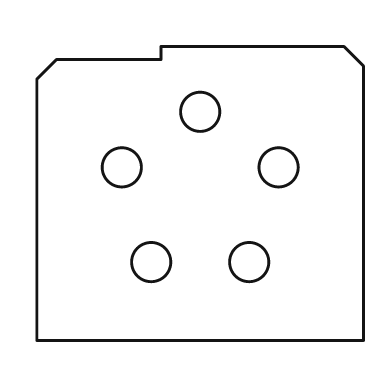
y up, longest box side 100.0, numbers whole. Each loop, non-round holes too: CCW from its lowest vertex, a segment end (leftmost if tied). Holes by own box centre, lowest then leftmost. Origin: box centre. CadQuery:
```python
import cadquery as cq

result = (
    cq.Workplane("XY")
    .moveTo(-50.0, -45.0)
    .lineTo(50.0, -45.0)
    .lineTo(50.0, 39.0)
    .lineTo(44.0, 45.0)
    .lineTo(-12.0, 45.0)
    .lineTo(-12.0, 41.0)
    .lineTo(-44.0, 41.0)
    .lineTo(-50.0, 35.0)
    .close()
    .moveTo(-15.0, -21.0)
    .circle(6.0)
    .moveTo(15.0, -21.0)
    .circle(6.0)
    .moveTo(-24.0, 8.0)
    .circle(6.0)
    .moveTo(24.0, 8.0)
    .circle(6.0)
    .moveTo(0.0, 25.0)
    .circle(6.0)
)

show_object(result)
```